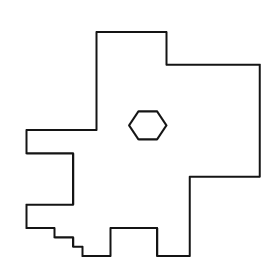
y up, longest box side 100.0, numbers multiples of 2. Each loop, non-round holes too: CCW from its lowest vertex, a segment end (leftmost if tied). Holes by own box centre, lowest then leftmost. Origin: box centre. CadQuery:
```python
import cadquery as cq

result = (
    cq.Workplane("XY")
    .moveTo(-26.0, -48.0)
    .lineTo(-14.0, -48.0)
    .lineTo(-14.0, -36.0)
    .lineTo(6.0, -36.0)
    .lineTo(6.0, -48.0)
    .lineTo(20.0, -48.0)
    .lineTo(20.0, -14.0)
    .lineTo(50.0, -14.0)
    .lineTo(50.0, 34.0)
    .lineTo(10.0, 34.0)
    .lineTo(10.0, 48.0)
    .lineTo(-20.0, 48.0)
    .lineTo(-20.0, 6.0)
    .lineTo(-50.0, 6.0)
    .lineTo(-50.0, -4.0)
    .lineTo(-30.0, -4.0)
    .lineTo(-30.0, -26.0)
    .lineTo(-50.0, -26.0)
    .lineTo(-50.0, -36.0)
    .lineTo(-38.0, -36.0)
    .lineTo(-38.0, -40.0)
    .lineTo(-30.0, -40.0)
    .lineTo(-30.0, -44.0)
    .lineTo(-26.0, -44.0)
    .close()
    .moveTo(-2.0, 2.0)
    .lineTo(6.0, 2.0)
    .lineTo(10.0, 8.0)
    .lineTo(6.0, 14.0)
    .lineTo(-2.0, 14.0)
    .lineTo(-6.0, 8.0)
    .close()
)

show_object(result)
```